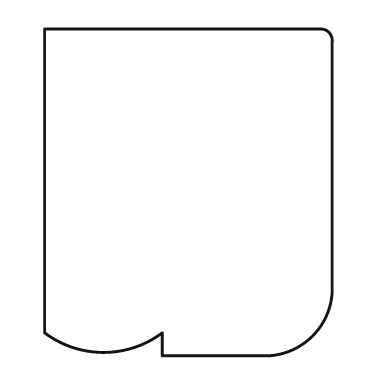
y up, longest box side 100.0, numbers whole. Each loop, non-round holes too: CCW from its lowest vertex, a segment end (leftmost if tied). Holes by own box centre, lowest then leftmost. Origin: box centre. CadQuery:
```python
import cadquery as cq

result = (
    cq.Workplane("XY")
    .moveTo(-8.0, -50.0)
    .lineTo(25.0, -50.0)
    .threePointArc((38.0, -44.0), (44.0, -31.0))
    .lineTo(44.0, 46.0)
    .threePointArc((43.0, 49.0), (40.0, 50.0))
    .lineTo(-44.0, 50.0)
    .lineTo(-44.0, -43.0)
    .threePointArc((-26.0, -49.0), (-8.0, -43.0))
    .close()
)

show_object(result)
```